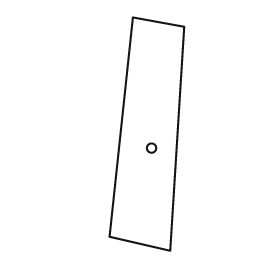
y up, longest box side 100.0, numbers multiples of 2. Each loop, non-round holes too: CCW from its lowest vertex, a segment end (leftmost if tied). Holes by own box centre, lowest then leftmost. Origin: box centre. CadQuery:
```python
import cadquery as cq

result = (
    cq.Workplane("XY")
    .moveTo(10.0, -50.0)
    .lineTo(16.0, 46.0)
    .lineTo(-6.0, 50.0)
    .lineTo(-16.0, -44.0)
    .close()
    .moveTo(2.0, -6.0)
    .circle(2.0)
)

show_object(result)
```